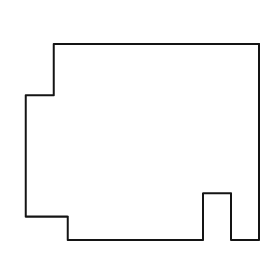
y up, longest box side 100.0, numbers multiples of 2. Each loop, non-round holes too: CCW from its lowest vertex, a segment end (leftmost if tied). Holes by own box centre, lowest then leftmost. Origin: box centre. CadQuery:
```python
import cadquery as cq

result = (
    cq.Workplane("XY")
    .moveTo(-32.0, -42.0)
    .lineTo(26.0, -42.0)
    .lineTo(26.0, -22.0)
    .lineTo(38.0, -22.0)
    .lineTo(38.0, -42.0)
    .lineTo(50.0, -42.0)
    .lineTo(50.0, 42.0)
    .lineTo(-38.0, 42.0)
    .lineTo(-38.0, 20.0)
    .lineTo(-50.0, 20.0)
    .lineTo(-50.0, -32.0)
    .lineTo(-32.0, -32.0)
    .close()
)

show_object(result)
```